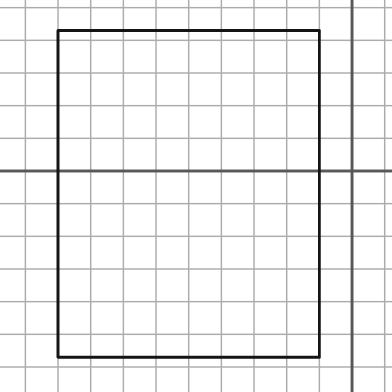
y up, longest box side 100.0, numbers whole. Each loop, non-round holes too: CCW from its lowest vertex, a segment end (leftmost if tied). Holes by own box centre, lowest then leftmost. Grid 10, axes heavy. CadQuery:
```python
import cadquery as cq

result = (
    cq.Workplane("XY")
    .moveTo(-90.0, -57.0)
    .lineTo(-10.0, -57.0)
    .lineTo(-10.0, 43.0)
    .lineTo(-90.0, 43.0)
    .close()
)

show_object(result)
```